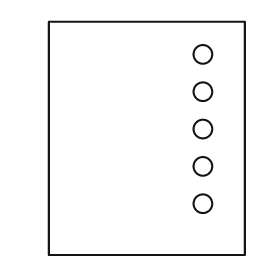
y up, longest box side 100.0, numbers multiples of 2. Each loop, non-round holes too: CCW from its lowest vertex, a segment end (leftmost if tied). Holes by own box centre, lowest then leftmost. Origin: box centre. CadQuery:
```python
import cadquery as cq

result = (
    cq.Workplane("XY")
    .moveTo(-42.0, -50.0)
    .lineTo(42.0, -50.0)
    .lineTo(42.0, 50.0)
    .lineTo(-42.0, 50.0)
    .close()
    .moveTo(24.0, -28.0)
    .circle(4.0)
    .moveTo(24.0, -12.0)
    .circle(4.0)
    .moveTo(24.0, 4.0)
    .circle(4.0)
    .moveTo(24.0, 20.0)
    .circle(4.0)
    .moveTo(24.0, 36.0)
    .circle(4.0)
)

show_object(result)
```